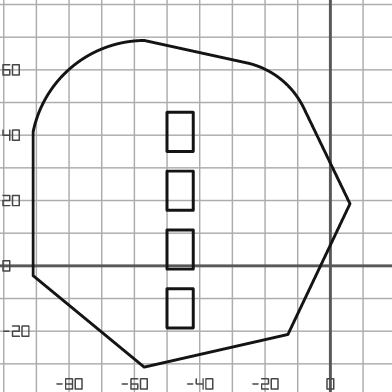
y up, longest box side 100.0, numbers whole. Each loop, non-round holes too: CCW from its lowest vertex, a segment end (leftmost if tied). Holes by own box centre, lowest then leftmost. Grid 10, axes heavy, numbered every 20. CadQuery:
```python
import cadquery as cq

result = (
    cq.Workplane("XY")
    .moveTo(-57.0, -31.0)
    .lineTo(-13.0, -21.0)
    .lineTo(6.0, 19.0)
    .lineTo(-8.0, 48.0)
    .threePointArc((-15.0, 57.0), (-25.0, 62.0))
    .lineTo(-57.0, 69.0)
    .threePointArc((-79.0, 61.0), (-91.0, 41.0))
    .lineTo(-91.0, -3.0)
    .close()
    .moveTo(-50.0, -19.0)
    .lineTo(-42.0, -19.0)
    .lineTo(-42.0, -7.0)
    .lineTo(-50.0, -7.0)
    .close()
    .moveTo(-50.0, -1.0)
    .lineTo(-42.0, -1.0)
    .lineTo(-42.0, 11.0)
    .lineTo(-50.0, 11.0)
    .close()
    .moveTo(-50.0, 17.0)
    .lineTo(-42.0, 17.0)
    .lineTo(-42.0, 29.0)
    .lineTo(-50.0, 29.0)
    .close()
    .moveTo(-50.0, 35.0)
    .lineTo(-42.0, 35.0)
    .lineTo(-42.0, 47.0)
    .lineTo(-50.0, 47.0)
    .close()
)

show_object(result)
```